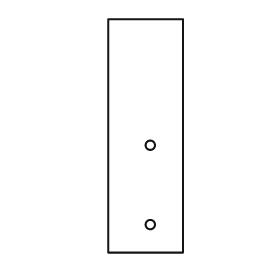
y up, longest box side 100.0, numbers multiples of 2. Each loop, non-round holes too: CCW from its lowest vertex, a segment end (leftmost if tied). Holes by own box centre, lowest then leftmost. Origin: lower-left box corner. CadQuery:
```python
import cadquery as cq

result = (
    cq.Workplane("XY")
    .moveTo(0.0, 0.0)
    .lineTo(32.0, 0.0)
    .lineTo(32.0, 100.0)
    .lineTo(0.0, 100.0)
    .close()
    .moveTo(18.0, 12.0)
    .circle(2.0)
    .moveTo(18.0, 46.0)
    .circle(2.0)
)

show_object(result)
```